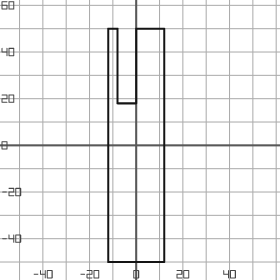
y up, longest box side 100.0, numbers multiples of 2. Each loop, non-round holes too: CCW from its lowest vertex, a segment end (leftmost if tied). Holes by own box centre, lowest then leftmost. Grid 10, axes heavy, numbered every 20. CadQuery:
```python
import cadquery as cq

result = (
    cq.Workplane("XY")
    .moveTo(-12.0, -50.0)
    .lineTo(12.0, -50.0)
    .lineTo(12.0, 50.0)
    .lineTo(0.0, 50.0)
    .lineTo(0.0, 18.0)
    .lineTo(-8.0, 18.0)
    .lineTo(-8.0, 50.0)
    .lineTo(-12.0, 50.0)
    .close()
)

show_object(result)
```